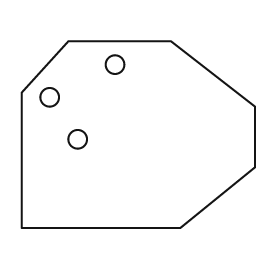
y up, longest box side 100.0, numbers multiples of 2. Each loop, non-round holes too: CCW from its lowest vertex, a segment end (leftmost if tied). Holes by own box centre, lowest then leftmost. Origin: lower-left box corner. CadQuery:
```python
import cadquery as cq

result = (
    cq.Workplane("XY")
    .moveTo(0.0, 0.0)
    .lineTo(68.0, 0.0)
    .lineTo(100.0, 26.0)
    .lineTo(100.0, 52.0)
    .lineTo(64.0, 80.0)
    .lineTo(20.0, 80.0)
    .lineTo(0.0, 58.0)
    .close()
    .moveTo(24.0, 38.0)
    .circle(4.0)
    .moveTo(12.0, 56.0)
    .circle(4.0)
    .moveTo(40.0, 70.0)
    .circle(4.0)
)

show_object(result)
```